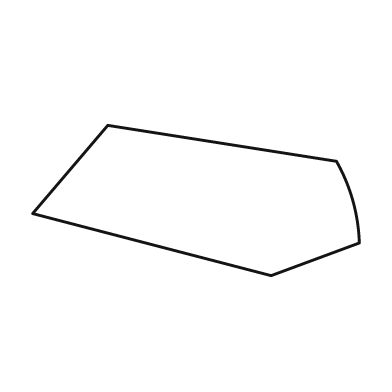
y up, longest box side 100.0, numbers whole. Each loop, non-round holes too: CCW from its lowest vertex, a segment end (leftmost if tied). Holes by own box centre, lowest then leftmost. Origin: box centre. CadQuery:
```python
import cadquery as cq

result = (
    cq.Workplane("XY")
    .moveTo(23.0, -23.0)
    .lineTo(50.0, -13.0)
    .threePointArc((48.0, 0.0), (43.0, 12.0))
    .lineTo(-27.0, 23.0)
    .lineTo(-50.0, -4.0)
    .close()
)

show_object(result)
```